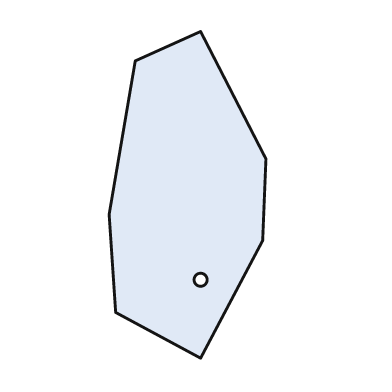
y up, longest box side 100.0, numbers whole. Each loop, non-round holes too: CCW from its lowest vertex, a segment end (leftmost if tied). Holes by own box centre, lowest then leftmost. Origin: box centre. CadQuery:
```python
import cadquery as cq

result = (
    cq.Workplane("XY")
    .moveTo(4.0, -50.0)
    .lineTo(23.0, -14.0)
    .lineTo(24.0, 11.0)
    .lineTo(4.0, 50.0)
    .lineTo(-16.0, 41.0)
    .lineTo(-24.0, -6.0)
    .lineTo(-22.0, -36.0)
    .close()
    .moveTo(4.0, -26.0)
    .circle(2.0)
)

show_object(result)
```